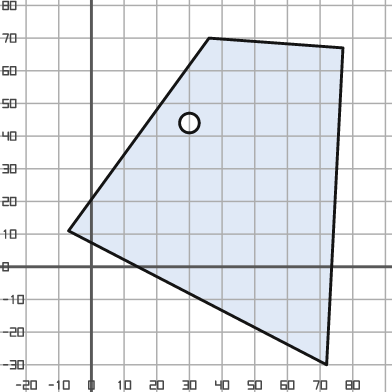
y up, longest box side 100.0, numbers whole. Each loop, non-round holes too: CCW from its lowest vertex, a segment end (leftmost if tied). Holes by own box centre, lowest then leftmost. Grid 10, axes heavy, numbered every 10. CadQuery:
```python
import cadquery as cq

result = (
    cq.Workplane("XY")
    .moveTo(72.0, -30.0)
    .lineTo(77.0, 67.0)
    .lineTo(36.0, 70.0)
    .lineTo(-7.0, 11.0)
    .close()
    .moveTo(30.0, 44.0)
    .circle(3.0)
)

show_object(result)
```